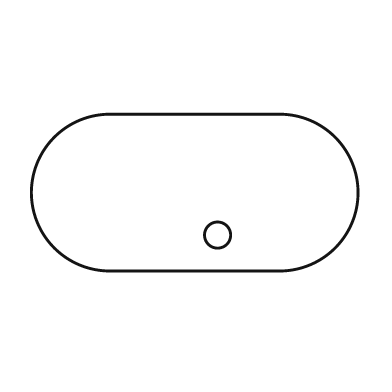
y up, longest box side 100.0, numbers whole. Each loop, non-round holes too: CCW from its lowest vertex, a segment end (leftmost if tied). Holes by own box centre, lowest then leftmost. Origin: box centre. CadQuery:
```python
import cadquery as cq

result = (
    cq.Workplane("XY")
    .moveTo(-26.0, -24.0)
    .lineTo(26.0, -24.0)
    .threePointArc((50.0, 0.0), (26.0, 24.0))
    .lineTo(-26.0, 24.0)
    .threePointArc((-50.0, 0.0), (-26.0, -24.0))
    .close()
    .moveTo(7.0, -13.0)
    .circle(4.0)
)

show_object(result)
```